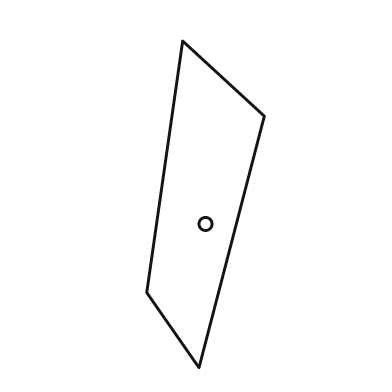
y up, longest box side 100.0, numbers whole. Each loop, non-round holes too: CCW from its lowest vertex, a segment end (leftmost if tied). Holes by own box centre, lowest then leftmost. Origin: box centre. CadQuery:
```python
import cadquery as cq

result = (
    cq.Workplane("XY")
    .moveTo(-2.0, -50.0)
    .lineTo(18.0, 27.0)
    .lineTo(-7.0, 50.0)
    .lineTo(-18.0, -27.0)
    .close()
    .moveTo(0.0, -6.0)
    .circle(2.0)
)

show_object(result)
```